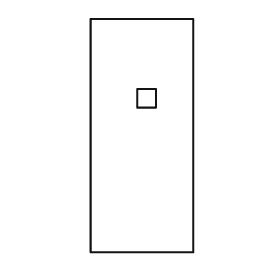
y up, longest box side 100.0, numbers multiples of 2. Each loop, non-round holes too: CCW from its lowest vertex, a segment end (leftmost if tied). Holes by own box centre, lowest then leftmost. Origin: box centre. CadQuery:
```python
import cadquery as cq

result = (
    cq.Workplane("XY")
    .moveTo(-22.0, -50.0)
    .lineTo(22.0, -50.0)
    .lineTo(22.0, 50.0)
    .lineTo(-22.0, 50.0)
    .close()
    .moveTo(-2.0, 12.0)
    .lineTo(6.0, 12.0)
    .lineTo(6.0, 20.0)
    .lineTo(-2.0, 20.0)
    .close()
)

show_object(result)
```